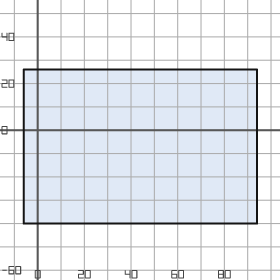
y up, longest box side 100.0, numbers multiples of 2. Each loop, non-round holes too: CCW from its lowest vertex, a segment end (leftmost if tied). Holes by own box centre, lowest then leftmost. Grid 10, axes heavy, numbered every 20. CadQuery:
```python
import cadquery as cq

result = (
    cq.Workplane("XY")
    .moveTo(-6.0, -40.0)
    .lineTo(94.0, -40.0)
    .lineTo(94.0, 26.0)
    .lineTo(-6.0, 26.0)
    .close()
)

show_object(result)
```